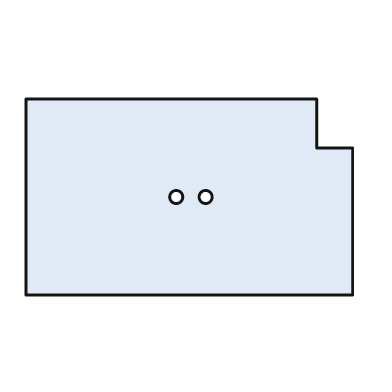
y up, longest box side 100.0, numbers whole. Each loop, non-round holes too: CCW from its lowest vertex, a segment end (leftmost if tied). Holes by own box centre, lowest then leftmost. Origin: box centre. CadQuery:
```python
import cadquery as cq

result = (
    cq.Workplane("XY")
    .moveTo(-50.0, -30.0)
    .lineTo(50.0, -30.0)
    .lineTo(50.0, 15.0)
    .lineTo(39.0, 15.0)
    .lineTo(39.0, 30.0)
    .lineTo(-50.0, 30.0)
    .close()
    .moveTo(-4.0, 0.0)
    .circle(2.0)
    .moveTo(5.0, 0.0)
    .circle(2.0)
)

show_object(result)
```